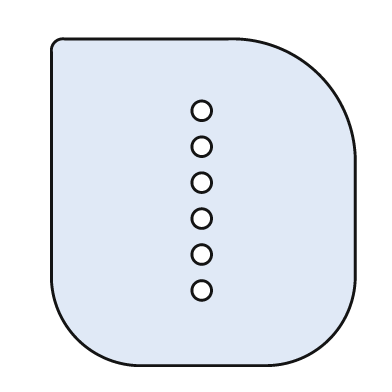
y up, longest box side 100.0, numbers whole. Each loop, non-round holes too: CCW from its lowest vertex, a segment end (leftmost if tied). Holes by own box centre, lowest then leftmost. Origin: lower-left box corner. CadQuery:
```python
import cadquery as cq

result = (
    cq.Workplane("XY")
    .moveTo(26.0, 0.0)
    .lineTo(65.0, 0.0)
    .threePointArc((85.0, 8.0), (93.0, 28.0))
    .lineTo(93.0, 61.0)
    .threePointArc((82.0, 89.0), (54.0, 100.0))
    .lineTo(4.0, 100.0)
    .threePointArc((1.0, 99.0), (0.0, 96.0))
    .lineTo(0.0, 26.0)
    .threePointArc((8.0, 8.0), (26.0, 0.0))
    .close()
    .moveTo(46.0, 23.0)
    .circle(3.0)
    .moveTo(46.0, 34.0)
    .circle(3.0)
    .moveTo(46.0, 45.0)
    .circle(3.0)
    .moveTo(46.0, 56.0)
    .circle(3.0)
    .moveTo(46.0, 67.0)
    .circle(3.0)
    .moveTo(46.0, 78.0)
    .circle(3.0)
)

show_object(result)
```